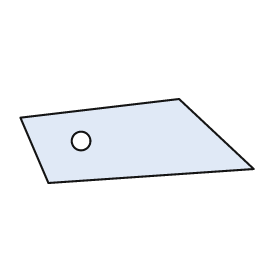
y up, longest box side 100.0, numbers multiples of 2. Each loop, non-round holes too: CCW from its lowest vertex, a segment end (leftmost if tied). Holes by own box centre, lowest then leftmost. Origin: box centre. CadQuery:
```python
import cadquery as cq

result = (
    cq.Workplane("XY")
    .moveTo(-38.0, -18.0)
    .lineTo(50.0, -12.0)
    .lineTo(18.0, 18.0)
    .lineTo(-50.0, 10.0)
    .close()
    .moveTo(-24.0, 0.0)
    .circle(4.0)
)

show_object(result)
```